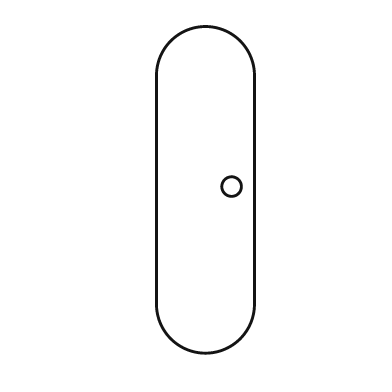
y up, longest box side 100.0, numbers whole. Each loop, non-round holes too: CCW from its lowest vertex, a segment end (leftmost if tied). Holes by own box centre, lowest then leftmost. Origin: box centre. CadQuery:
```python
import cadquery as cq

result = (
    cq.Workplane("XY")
    .moveTo(-15.0, -35.0)
    .threePointArc((0.0, -50.0), (15.0, -35.0))
    .lineTo(15.0, 35.0)
    .threePointArc((0.0, 50.0), (-15.0, 35.0))
    .close()
    .moveTo(8.0, 1.0)
    .circle(3.0)
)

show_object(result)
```